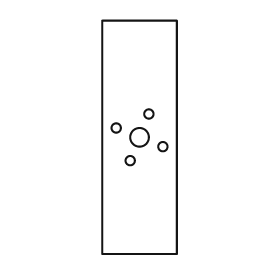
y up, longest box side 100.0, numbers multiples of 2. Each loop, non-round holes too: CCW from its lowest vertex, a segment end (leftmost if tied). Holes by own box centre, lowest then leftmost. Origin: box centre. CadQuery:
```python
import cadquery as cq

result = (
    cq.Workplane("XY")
    .moveTo(-16.0, -50.0)
    .lineTo(16.0, -50.0)
    .lineTo(16.0, 50.0)
    .lineTo(-16.0, 50.0)
    .close()
    .moveTo(-4.0, -10.0)
    .circle(2.0)
    .moveTo(10.0, -4.0)
    .circle(2.0)
    .moveTo(0.0, 0.0)
    .circle(4.0)
    .moveTo(-10.0, 4.0)
    .circle(2.0)
    .moveTo(4.0, 10.0)
    .circle(2.0)
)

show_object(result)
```